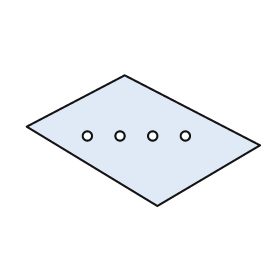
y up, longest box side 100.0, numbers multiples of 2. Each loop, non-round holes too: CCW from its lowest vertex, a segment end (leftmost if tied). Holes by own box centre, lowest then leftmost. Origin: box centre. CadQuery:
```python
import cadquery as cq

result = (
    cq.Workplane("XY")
    .moveTo(6.0, -28.0)
    .lineTo(50.0, -2.0)
    .lineTo(-8.0, 28.0)
    .lineTo(-50.0, 6.0)
    .close()
    .moveTo(-24.0, 2.0)
    .circle(2.0)
    .moveTo(-10.0, 2.0)
    .circle(2.0)
    .moveTo(4.0, 2.0)
    .circle(2.0)
    .moveTo(18.0, 2.0)
    .circle(2.0)
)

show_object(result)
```